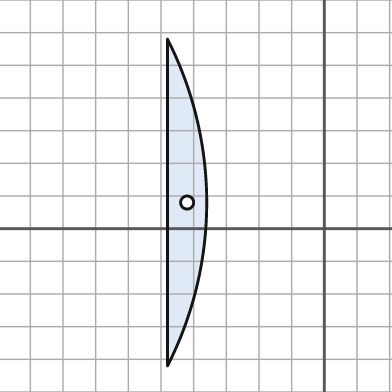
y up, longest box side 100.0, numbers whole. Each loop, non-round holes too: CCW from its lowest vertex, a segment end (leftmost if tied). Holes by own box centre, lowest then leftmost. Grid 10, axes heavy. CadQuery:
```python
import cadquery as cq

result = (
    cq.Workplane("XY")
    .moveTo(-48.0, -42.0)
    .threePointArc((-36.0, 8.0), (-48.0, 58.0))
    .close()
    .moveTo(-42.0, 8.0)
    .circle(2.0)
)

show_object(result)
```